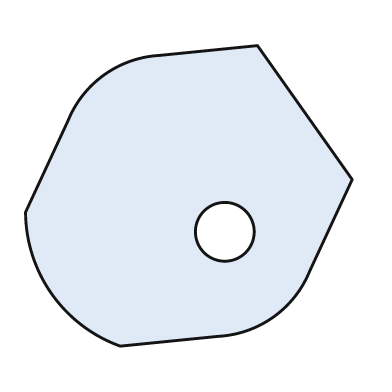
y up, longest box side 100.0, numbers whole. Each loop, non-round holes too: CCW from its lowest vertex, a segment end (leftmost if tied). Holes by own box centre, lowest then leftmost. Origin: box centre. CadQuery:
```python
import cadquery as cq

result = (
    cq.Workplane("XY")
    .moveTo(-21.0, -46.0)
    .lineTo(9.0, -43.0)
    .threePointArc((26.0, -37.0), (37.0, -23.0))
    .lineTo(50.0, 5.0)
    .lineTo(21.0, 46.0)
    .lineTo(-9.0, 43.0)
    .threePointArc((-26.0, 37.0), (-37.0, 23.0))
    .lineTo(-50.0, -5.0)
    .threePointArc((-42.0, -30.0), (-21.0, -46.0))
    .close()
    .moveTo(11.0, -11.0)
    .circle(9.0)
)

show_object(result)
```